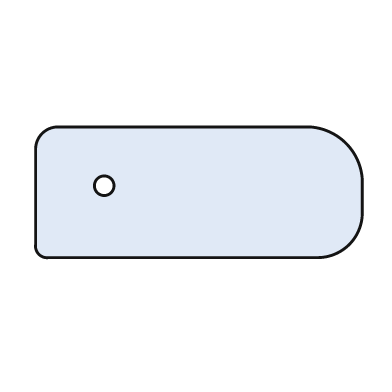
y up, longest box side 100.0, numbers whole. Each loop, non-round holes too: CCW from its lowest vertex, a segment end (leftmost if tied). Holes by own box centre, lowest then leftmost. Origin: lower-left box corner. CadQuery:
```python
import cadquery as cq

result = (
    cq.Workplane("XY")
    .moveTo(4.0, 0.0)
    .lineTo(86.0, 0.0)
    .threePointArc((96.0, 4.0), (100.0, 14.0))
    .lineTo(100.0, 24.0)
    .threePointArc((95.0, 35.0), (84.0, 40.0))
    .lineTo(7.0, 40.0)
    .threePointArc((2.0, 38.0), (0.0, 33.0))
    .lineTo(0.0, 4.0)
    .threePointArc((1.0, 1.0), (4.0, 0.0))
    .close()
    .moveTo(21.0, 22.0)
    .circle(3.0)
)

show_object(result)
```